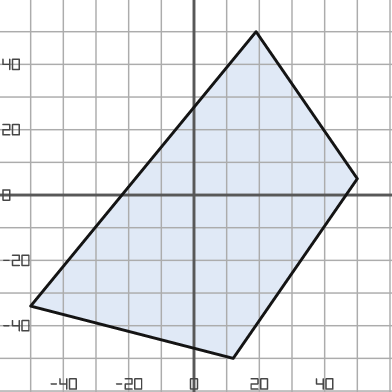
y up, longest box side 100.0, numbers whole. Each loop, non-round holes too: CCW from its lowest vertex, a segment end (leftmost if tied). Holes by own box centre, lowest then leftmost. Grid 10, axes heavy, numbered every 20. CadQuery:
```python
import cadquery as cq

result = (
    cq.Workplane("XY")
    .moveTo(12.0, -50.0)
    .lineTo(50.0, 5.0)
    .lineTo(19.0, 50.0)
    .lineTo(-50.0, -34.0)
    .close()
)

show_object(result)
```